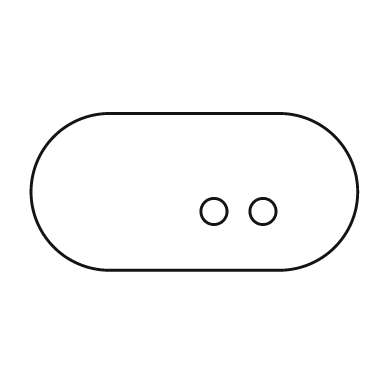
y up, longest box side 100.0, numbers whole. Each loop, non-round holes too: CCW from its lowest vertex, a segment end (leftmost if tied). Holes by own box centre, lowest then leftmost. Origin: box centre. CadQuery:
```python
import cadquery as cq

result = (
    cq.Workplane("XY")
    .moveTo(-26.0, -24.0)
    .lineTo(26.0, -24.0)
    .threePointArc((50.0, 0.0), (26.0, 24.0))
    .lineTo(-26.0, 24.0)
    .threePointArc((-50.0, 0.0), (-26.0, -24.0))
    .close()
    .moveTo(6.0, -6.0)
    .circle(4.0)
    .moveTo(21.0, -6.0)
    .circle(4.0)
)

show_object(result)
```